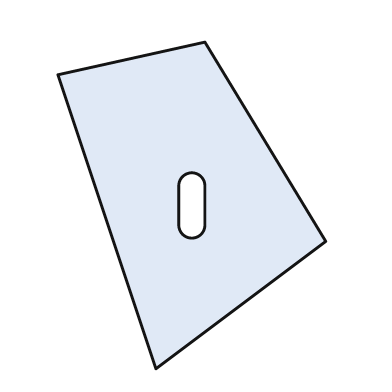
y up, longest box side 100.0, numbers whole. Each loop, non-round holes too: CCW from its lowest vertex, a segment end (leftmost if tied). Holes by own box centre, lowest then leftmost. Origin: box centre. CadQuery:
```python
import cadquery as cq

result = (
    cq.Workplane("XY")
    .moveTo(-11.0, -50.0)
    .lineTo(41.0, -11.0)
    .lineTo(4.0, 50.0)
    .lineTo(-41.0, 40.0)
    .close()
    .moveTo(-4.0, -6.0)
    .threePointArc((0.0, -10.0), (4.0, -6.0))
    .lineTo(4.0, 6.0)
    .threePointArc((0.0, 10.0), (-4.0, 6.0))
    .close()
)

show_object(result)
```